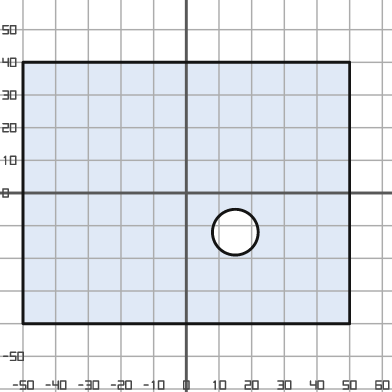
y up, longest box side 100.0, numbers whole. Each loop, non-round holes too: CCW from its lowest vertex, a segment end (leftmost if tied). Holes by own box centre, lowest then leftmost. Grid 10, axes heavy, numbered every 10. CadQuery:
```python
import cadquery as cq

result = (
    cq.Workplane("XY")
    .moveTo(-50.0, -40.0)
    .lineTo(50.0, -40.0)
    .lineTo(50.0, 40.0)
    .lineTo(-50.0, 40.0)
    .close()
    .moveTo(15.0, -12.0)
    .circle(7.0)
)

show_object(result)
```